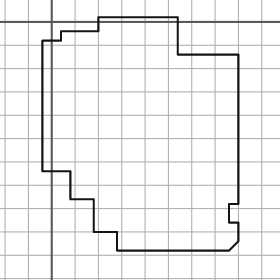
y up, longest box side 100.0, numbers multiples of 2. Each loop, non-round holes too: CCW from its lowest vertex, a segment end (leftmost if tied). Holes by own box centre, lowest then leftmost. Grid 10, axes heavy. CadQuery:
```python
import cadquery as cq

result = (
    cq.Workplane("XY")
    .moveTo(28.0, -98.0)
    .lineTo(76.0, -98.0)
    .lineTo(80.0, -94.0)
    .lineTo(80.0, -86.0)
    .lineTo(76.0, -86.0)
    .lineTo(76.0, -78.0)
    .lineTo(80.0, -78.0)
    .lineTo(80.0, -14.0)
    .lineTo(54.0, -14.0)
    .lineTo(54.0, 2.0)
    .lineTo(20.0, 2.0)
    .lineTo(20.0, -4.0)
    .lineTo(4.0, -4.0)
    .lineTo(4.0, -8.0)
    .lineTo(-4.0, -8.0)
    .lineTo(-4.0, -64.0)
    .lineTo(8.0, -64.0)
    .lineTo(8.0, -76.0)
    .lineTo(18.0, -76.0)
    .lineTo(18.0, -90.0)
    .lineTo(28.0, -90.0)
    .close()
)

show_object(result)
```